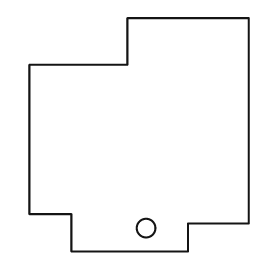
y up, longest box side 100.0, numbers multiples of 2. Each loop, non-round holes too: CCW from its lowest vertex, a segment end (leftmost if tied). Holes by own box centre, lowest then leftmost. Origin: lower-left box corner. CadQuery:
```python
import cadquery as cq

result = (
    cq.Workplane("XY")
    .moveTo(18.0, 0.0)
    .lineTo(68.0, 0.0)
    .lineTo(68.0, 12.0)
    .lineTo(94.0, 12.0)
    .lineTo(94.0, 100.0)
    .lineTo(42.0, 100.0)
    .lineTo(42.0, 80.0)
    .lineTo(0.0, 80.0)
    .lineTo(0.0, 16.0)
    .lineTo(18.0, 16.0)
    .close()
    .moveTo(50.0, 10.0)
    .circle(4.0)
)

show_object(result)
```